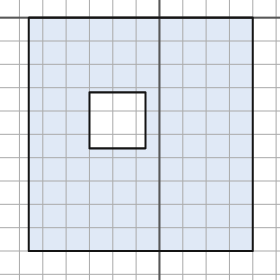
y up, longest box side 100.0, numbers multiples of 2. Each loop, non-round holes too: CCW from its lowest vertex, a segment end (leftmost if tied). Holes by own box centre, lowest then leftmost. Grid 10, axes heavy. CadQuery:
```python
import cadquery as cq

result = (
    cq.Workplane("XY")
    .moveTo(-56.0, -100.0)
    .lineTo(40.0, -100.0)
    .lineTo(40.0, 0.0)
    .lineTo(-56.0, 0.0)
    .close()
    .moveTo(-30.0, -56.0)
    .lineTo(-6.0, -56.0)
    .lineTo(-6.0, -32.0)
    .lineTo(-30.0, -32.0)
    .close()
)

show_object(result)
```